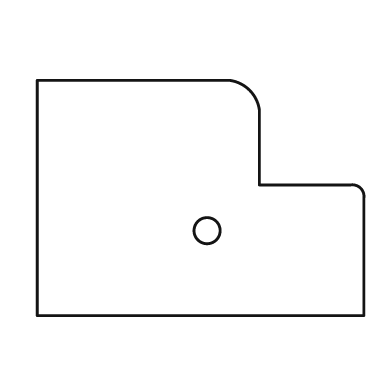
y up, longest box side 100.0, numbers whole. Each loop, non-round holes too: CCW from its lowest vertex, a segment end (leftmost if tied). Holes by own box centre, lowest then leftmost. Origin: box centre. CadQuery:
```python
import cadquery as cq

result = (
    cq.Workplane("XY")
    .moveTo(-50.0, -36.0)
    .lineTo(50.0, -36.0)
    .lineTo(50.0, 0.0)
    .threePointArc((49.0, 3.0), (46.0, 4.0))
    .lineTo(18.0, 4.0)
    .lineTo(18.0, 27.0)
    .threePointArc((15.0, 33.0), (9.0, 36.0))
    .lineTo(-50.0, 36.0)
    .close()
    .moveTo(2.0, -10.0)
    .circle(4.0)
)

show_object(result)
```